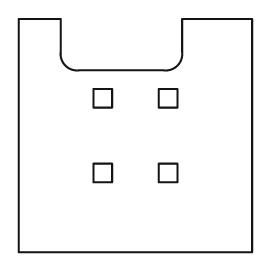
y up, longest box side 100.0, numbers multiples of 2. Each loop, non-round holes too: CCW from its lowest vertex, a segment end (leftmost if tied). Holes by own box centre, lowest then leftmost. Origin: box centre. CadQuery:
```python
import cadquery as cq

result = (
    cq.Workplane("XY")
    .moveTo(-50.0, -50.0)
    .lineTo(50.0, -50.0)
    .lineTo(50.0, 50.0)
    .lineTo(20.0, 50.0)
    .lineTo(20.0, 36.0)
    .threePointArc((18.0, 30.0), (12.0, 28.0))
    .lineTo(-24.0, 28.0)
    .threePointArc((-30.0, 30.0), (-32.0, 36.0))
    .lineTo(-32.0, 50.0)
    .lineTo(-50.0, 50.0)
    .close()
    .moveTo(-18.0, -20.0)
    .lineTo(-10.0, -20.0)
    .lineTo(-10.0, -12.0)
    .lineTo(-18.0, -12.0)
    .close()
    .moveTo(10.0, -20.0)
    .lineTo(18.0, -20.0)
    .lineTo(18.0, -12.0)
    .lineTo(10.0, -12.0)
    .close()
    .moveTo(-18.0, 12.0)
    .lineTo(-10.0, 12.0)
    .lineTo(-10.0, 20.0)
    .lineTo(-18.0, 20.0)
    .close()
    .moveTo(10.0, 12.0)
    .lineTo(18.0, 12.0)
    .lineTo(18.0, 20.0)
    .lineTo(10.0, 20.0)
    .close()
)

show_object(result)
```